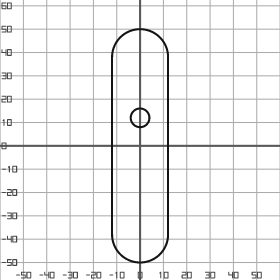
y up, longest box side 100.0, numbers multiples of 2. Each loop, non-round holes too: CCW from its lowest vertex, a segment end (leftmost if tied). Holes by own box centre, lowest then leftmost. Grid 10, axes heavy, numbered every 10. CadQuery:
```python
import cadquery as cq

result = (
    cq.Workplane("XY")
    .moveTo(-12.0, -38.0)
    .threePointArc((0.0, -50.0), (12.0, -38.0))
    .lineTo(12.0, 38.0)
    .threePointArc((0.0, 50.0), (-12.0, 38.0))
    .close()
    .moveTo(0.0, 12.0)
    .circle(4.0)
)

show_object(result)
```